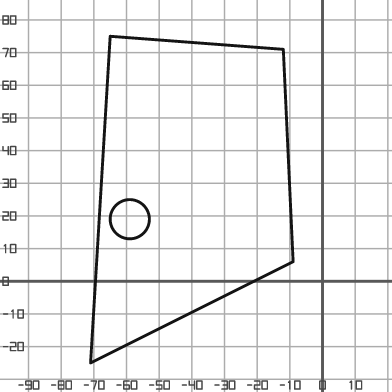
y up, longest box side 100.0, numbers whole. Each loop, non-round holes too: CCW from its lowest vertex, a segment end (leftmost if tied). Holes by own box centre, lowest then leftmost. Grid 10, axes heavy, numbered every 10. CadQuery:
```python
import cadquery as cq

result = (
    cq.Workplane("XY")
    .moveTo(-71.0, -25.0)
    .lineTo(-9.0, 6.0)
    .lineTo(-12.0, 71.0)
    .lineTo(-65.0, 75.0)
    .close()
    .moveTo(-59.0, 19.0)
    .circle(6.0)
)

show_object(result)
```